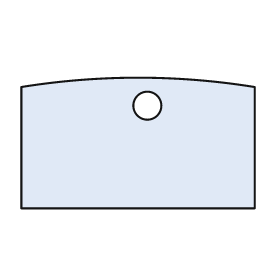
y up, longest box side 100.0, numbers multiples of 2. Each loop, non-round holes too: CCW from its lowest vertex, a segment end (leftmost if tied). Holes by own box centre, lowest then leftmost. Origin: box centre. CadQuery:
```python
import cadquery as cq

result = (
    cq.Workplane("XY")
    .moveTo(-50.0, -28.0)
    .lineTo(50.0, -28.0)
    .lineTo(50.0, 24.0)
    .threePointArc((0.0, 28.0), (-50.0, 24.0))
    .close()
    .moveTo(4.0, 16.0)
    .circle(6.0)
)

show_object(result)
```